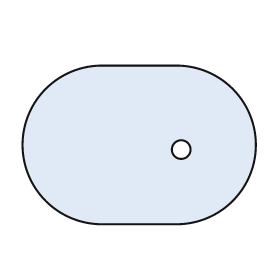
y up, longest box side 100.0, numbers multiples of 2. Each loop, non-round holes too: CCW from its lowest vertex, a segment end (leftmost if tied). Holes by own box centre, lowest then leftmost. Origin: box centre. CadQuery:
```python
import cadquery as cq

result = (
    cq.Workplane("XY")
    .moveTo(-16.0, -34.0)
    .lineTo(16.0, -34.0)
    .threePointArc((50.0, 0.0), (16.0, 34.0))
    .lineTo(-16.0, 34.0)
    .threePointArc((-50.0, 0.0), (-16.0, -34.0))
    .close()
    .moveTo(18.0, -2.0)
    .circle(4.0)
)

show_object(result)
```